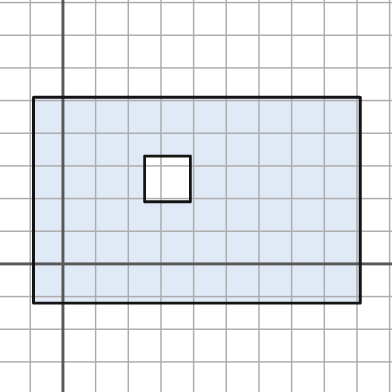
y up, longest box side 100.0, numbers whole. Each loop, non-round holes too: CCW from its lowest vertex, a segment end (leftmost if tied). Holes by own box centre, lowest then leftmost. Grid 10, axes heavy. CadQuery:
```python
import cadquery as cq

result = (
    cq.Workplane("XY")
    .moveTo(-9.0, -12.0)
    .lineTo(91.0, -12.0)
    .lineTo(91.0, 51.0)
    .lineTo(-9.0, 51.0)
    .close()
    .moveTo(25.0, 19.0)
    .lineTo(39.0, 19.0)
    .lineTo(39.0, 33.0)
    .lineTo(25.0, 33.0)
    .close()
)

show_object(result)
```